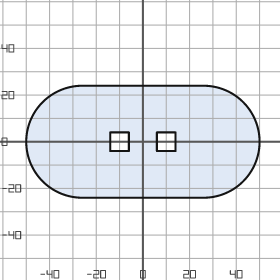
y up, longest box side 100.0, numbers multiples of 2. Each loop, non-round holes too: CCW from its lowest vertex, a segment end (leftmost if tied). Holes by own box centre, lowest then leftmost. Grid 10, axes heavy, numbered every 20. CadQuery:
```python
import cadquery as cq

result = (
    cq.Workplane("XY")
    .moveTo(-26.0, -24.0)
    .lineTo(26.0, -24.0)
    .threePointArc((50.0, 0.0), (26.0, 24.0))
    .lineTo(-26.0, 24.0)
    .threePointArc((-50.0, 0.0), (-26.0, -24.0))
    .close()
    .moveTo(-14.0, -4.0)
    .lineTo(-6.0, -4.0)
    .lineTo(-6.0, 4.0)
    .lineTo(-14.0, 4.0)
    .close()
    .moveTo(6.0, -4.0)
    .lineTo(14.0, -4.0)
    .lineTo(14.0, 4.0)
    .lineTo(6.0, 4.0)
    .close()
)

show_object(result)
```